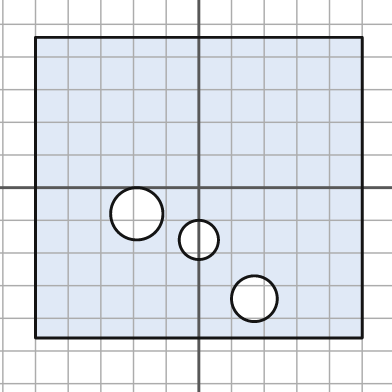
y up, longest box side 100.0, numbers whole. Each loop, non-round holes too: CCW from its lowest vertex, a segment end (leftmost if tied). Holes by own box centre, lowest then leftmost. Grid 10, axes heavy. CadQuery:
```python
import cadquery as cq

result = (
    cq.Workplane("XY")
    .moveTo(-50.0, -46.0)
    .lineTo(50.0, -46.0)
    .lineTo(50.0, 46.0)
    .lineTo(-50.0, 46.0)
    .close()
    .moveTo(17.0, -34.0)
    .circle(7.0)
    .moveTo(0.0, -16.0)
    .circle(6.0)
    .moveTo(-19.0, -8.0)
    .circle(8.0)
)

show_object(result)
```